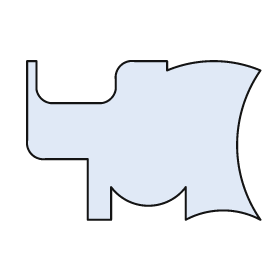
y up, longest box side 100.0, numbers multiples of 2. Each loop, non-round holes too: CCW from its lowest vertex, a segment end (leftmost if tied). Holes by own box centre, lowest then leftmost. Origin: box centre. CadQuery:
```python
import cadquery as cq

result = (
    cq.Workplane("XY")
    .moveTo(-24.0, -34.0)
    .lineTo(-14.0, -34.0)
    .lineTo(-14.0, -20.0)
    .threePointArc((2.0, -28.0), (18.0, -20.0))
    .lineTo(18.0, -34.0)
    .threePointArc((34.0, -30.0), (50.0, -34.0))
    .threePointArc((40.0, -2.0), (50.0, 30.0))
    .threePointArc((30.0, 34.0), (10.0, 30.0))
    .lineTo(10.0, 34.0)
    .lineTo(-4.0, 34.0)
    .threePointArc((-10.0, 32.0), (-12.0, 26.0))
    .lineTo(-12.0, 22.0)
    .threePointArc((-14.0, 18.0), (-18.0, 16.0))
    .lineTo(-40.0, 16.0)
    .threePointArc((-44.0, 18.0), (-46.0, 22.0))
    .lineTo(-46.0, 34.0)
    .lineTo(-50.0, 34.0)
    .lineTo(-50.0, 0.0)
    .threePointArc((-48.0, -6.0), (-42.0, -8.0))
    .lineTo(-24.0, -8.0)
    .close()
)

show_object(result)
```